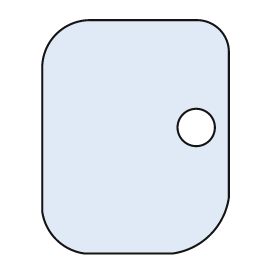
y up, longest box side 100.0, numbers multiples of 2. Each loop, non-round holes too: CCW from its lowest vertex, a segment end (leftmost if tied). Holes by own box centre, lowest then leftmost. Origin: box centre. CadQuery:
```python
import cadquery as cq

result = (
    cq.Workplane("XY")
    .moveTo(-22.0, -50.0)
    .lineTo(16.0, -50.0)
    .threePointArc((32.0, -42.0), (40.0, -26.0))
    .lineTo(40.0, 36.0)
    .threePointArc((36.0, 46.0), (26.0, 50.0))
    .lineTo(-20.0, 50.0)
    .threePointArc((-34.0, 44.0), (-40.0, 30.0))
    .lineTo(-40.0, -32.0)
    .threePointArc((-34.0, -44.0), (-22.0, -50.0))
    .close()
    .moveTo(26.0, 4.0)
    .circle(8.0)
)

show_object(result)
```